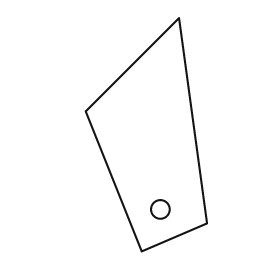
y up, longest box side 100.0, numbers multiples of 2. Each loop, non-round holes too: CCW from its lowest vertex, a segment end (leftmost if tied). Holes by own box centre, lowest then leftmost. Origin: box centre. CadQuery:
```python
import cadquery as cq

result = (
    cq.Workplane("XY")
    .moveTo(-2.0, -50.0)
    .lineTo(26.0, -38.0)
    .lineTo(14.0, 50.0)
    .lineTo(-26.0, 10.0)
    .close()
    .moveTo(6.0, -32.0)
    .circle(4.0)
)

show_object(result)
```